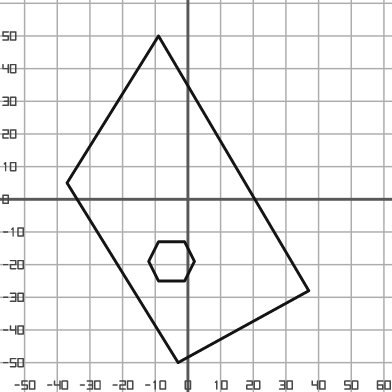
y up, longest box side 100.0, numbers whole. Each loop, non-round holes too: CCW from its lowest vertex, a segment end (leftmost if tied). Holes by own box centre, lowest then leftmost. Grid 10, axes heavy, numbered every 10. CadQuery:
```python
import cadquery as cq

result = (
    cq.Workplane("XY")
    .moveTo(-3.0, -50.0)
    .lineTo(37.0, -28.0)
    .lineTo(-9.0, 50.0)
    .lineTo(-37.0, 5.0)
    .close()
    .moveTo(-9.0, -25.0)
    .lineTo(-1.0, -25.0)
    .lineTo(2.0, -19.0)
    .lineTo(-1.0, -13.0)
    .lineTo(-9.0, -13.0)
    .lineTo(-12.0, -19.0)
    .close()
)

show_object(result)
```